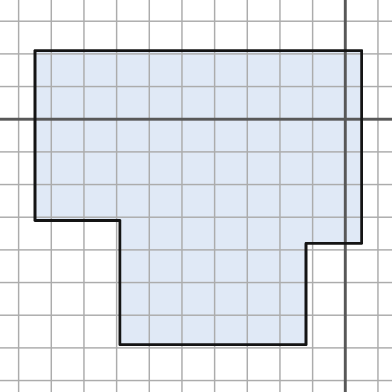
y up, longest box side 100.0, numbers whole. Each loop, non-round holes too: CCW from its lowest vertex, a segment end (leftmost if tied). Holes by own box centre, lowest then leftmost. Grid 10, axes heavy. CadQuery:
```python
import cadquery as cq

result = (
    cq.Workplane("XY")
    .moveTo(-69.0, -69.0)
    .lineTo(-12.0, -69.0)
    .lineTo(-12.0, -38.0)
    .lineTo(5.0, -38.0)
    .lineTo(5.0, 21.0)
    .lineTo(-95.0, 21.0)
    .lineTo(-95.0, -31.0)
    .lineTo(-69.0, -31.0)
    .close()
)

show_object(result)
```